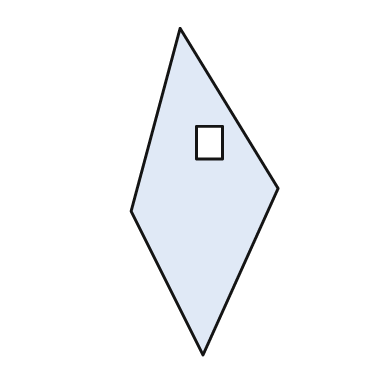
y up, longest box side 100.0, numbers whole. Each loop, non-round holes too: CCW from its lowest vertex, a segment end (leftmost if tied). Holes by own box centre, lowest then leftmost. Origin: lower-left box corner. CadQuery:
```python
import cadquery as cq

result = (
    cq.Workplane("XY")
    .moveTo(22.0, 0.0)
    .lineTo(45.0, 51.0)
    .lineTo(15.0, 100.0)
    .lineTo(0.0, 44.0)
    .close()
    .moveTo(20.0, 60.0)
    .lineTo(28.0, 60.0)
    .lineTo(28.0, 70.0)
    .lineTo(20.0, 70.0)
    .close()
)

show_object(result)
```